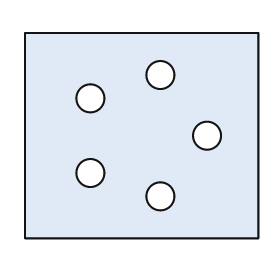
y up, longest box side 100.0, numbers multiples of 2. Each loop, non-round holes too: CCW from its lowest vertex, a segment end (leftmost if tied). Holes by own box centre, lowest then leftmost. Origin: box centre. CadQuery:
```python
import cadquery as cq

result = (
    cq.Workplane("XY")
    .moveTo(-50.0, -44.0)
    .lineTo(50.0, -44.0)
    .lineTo(50.0, 44.0)
    .lineTo(-50.0, 44.0)
    .close()
    .moveTo(8.0, -26.0)
    .circle(6.0)
    .moveTo(-22.0, -16.0)
    .circle(6.0)
    .moveTo(28.0, 0.0)
    .circle(6.0)
    .moveTo(-22.0, 16.0)
    .circle(6.0)
    .moveTo(8.0, 26.0)
    .circle(6.0)
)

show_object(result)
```